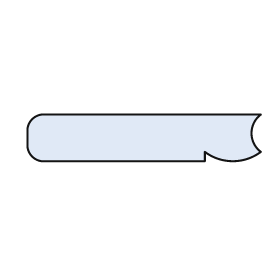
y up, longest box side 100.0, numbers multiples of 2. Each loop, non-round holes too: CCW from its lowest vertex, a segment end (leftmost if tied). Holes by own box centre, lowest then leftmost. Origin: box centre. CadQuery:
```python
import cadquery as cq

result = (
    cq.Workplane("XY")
    .moveTo(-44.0, -10.0)
    .lineTo(26.0, -10.0)
    .lineTo(26.0, -6.0)
    .threePointArc((38.0, -10.0), (50.0, -6.0))
    .threePointArc((46.0, 2.0), (50.0, 10.0))
    .lineTo(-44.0, 10.0)
    .threePointArc((-48.0, 8.0), (-50.0, 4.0))
    .lineTo(-50.0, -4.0)
    .threePointArc((-48.0, -8.0), (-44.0, -10.0))
    .close()
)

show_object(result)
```